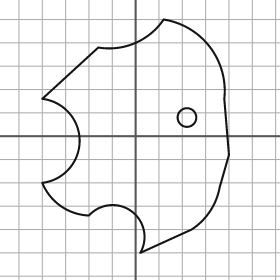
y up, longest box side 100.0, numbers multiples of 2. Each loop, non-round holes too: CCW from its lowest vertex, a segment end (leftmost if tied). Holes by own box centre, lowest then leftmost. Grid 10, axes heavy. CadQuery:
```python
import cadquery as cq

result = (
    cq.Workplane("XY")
    .moveTo(2.0, -50.0)
    .lineTo(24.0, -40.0)
    .threePointArc((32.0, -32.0), (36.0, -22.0))
    .lineTo(40.0, -8.0)
    .lineTo(38.0, 16.0)
    .threePointArc((32.0, 38.0), (12.0, 50.0))
    .threePointArc((0.0, 40.0), (-16.0, 38.0))
    .lineTo(-40.0, 16.0)
    .threePointArc((-24.0, -2.0), (-40.0, -20.0))
    .threePointArc((-32.0, -30.0), (-20.0, -34.0))
    .threePointArc((-2.0, -32.0), (2.0, -50.0))
    .close()
    .moveTo(22.0, 8.0)
    .circle(4.0)
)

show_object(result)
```